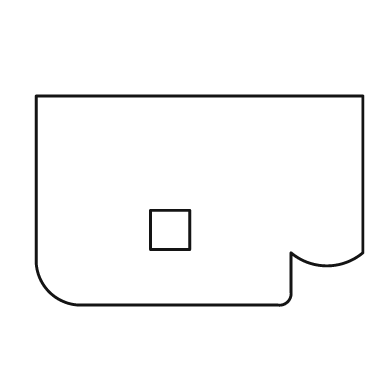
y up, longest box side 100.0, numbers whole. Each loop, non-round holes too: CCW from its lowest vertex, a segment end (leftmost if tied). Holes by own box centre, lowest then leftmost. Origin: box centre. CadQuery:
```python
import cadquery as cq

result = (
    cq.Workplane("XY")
    .moveTo(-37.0, -32.0)
    .lineTo(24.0, -32.0)
    .threePointArc((27.0, -31.0), (28.0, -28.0))
    .lineTo(28.0, -16.0)
    .threePointArc((39.0, -20.0), (50.0, -16.0))
    .lineTo(50.0, 32.0)
    .lineTo(-50.0, 32.0)
    .lineTo(-50.0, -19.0)
    .threePointArc((-46.0, -28.0), (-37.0, -32.0))
    .close()
    .moveTo(-15.0, -15.0)
    .lineTo(-3.0, -15.0)
    .lineTo(-3.0, -3.0)
    .lineTo(-15.0, -3.0)
    .close()
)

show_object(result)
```